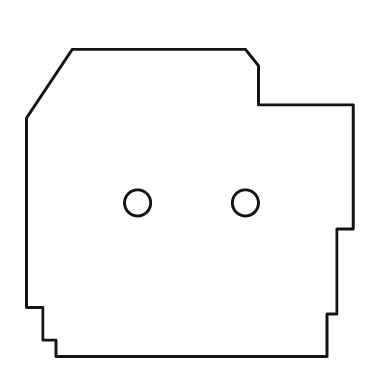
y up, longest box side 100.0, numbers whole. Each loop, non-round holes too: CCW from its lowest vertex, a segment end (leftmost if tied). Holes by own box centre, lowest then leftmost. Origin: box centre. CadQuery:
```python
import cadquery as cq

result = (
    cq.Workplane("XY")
    .moveTo(-41.0, -47.0)
    .lineTo(42.0, -47.0)
    .lineTo(42.0, -34.0)
    .lineTo(45.0, -34.0)
    .lineTo(45.0, -8.0)
    .lineTo(50.0, -8.0)
    .lineTo(50.0, 30.0)
    .lineTo(21.0, 30.0)
    .lineTo(21.0, 42.0)
    .lineTo(17.0, 47.0)
    .lineTo(-36.0, 47.0)
    .lineTo(-50.0, 26.0)
    .lineTo(-50.0, -32.0)
    .lineTo(-45.0, -32.0)
    .lineTo(-45.0, -42.0)
    .lineTo(-41.0, -42.0)
    .close()
    .moveTo(-16.0, 0.0)
    .circle(4.0)
    .moveTo(17.0, 0.0)
    .circle(4.0)
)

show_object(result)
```